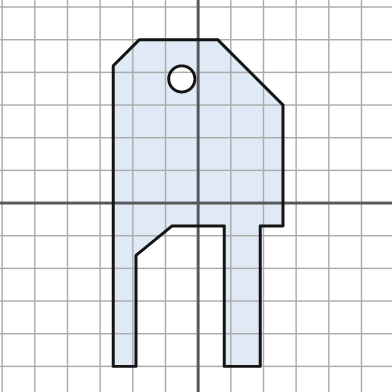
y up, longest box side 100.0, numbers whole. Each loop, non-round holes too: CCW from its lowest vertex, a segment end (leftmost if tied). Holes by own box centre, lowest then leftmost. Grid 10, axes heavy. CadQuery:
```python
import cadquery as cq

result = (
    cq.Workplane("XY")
    .moveTo(-26.0, -50.0)
    .lineTo(-19.0, -50.0)
    .lineTo(-19.0, -16.0)
    .lineTo(-8.0, -7.0)
    .lineTo(8.0, -7.0)
    .lineTo(8.0, -50.0)
    .lineTo(19.0, -50.0)
    .lineTo(19.0, -7.0)
    .lineTo(26.0, -7.0)
    .lineTo(26.0, 30.0)
    .lineTo(6.0, 50.0)
    .lineTo(-18.0, 50.0)
    .lineTo(-26.0, 42.0)
    .close()
    .moveTo(-5.0, 38.0)
    .circle(4.0)
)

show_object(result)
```